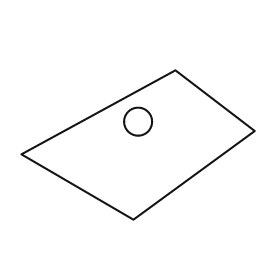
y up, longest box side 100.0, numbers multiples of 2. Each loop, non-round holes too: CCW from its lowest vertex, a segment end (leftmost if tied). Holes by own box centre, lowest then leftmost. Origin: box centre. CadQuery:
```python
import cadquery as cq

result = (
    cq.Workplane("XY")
    .moveTo(-2.0, -32.0)
    .lineTo(50.0, 6.0)
    .lineTo(16.0, 32.0)
    .lineTo(-50.0, -4.0)
    .close()
    .moveTo(0.0, 10.0)
    .circle(6.0)
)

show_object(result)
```